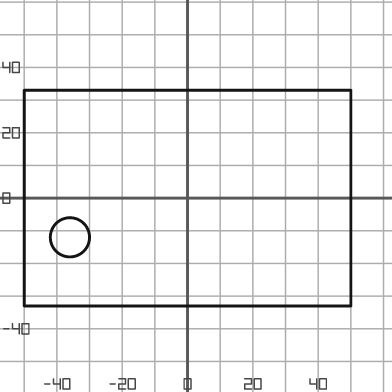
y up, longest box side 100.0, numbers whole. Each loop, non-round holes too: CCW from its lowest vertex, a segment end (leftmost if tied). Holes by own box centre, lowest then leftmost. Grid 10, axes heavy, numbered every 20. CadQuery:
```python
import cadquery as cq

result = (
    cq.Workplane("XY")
    .moveTo(-50.0, -33.0)
    .lineTo(50.0, -33.0)
    .lineTo(50.0, 33.0)
    .lineTo(-50.0, 33.0)
    .close()
    .moveTo(-36.0, -12.0)
    .circle(6.0)
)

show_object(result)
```